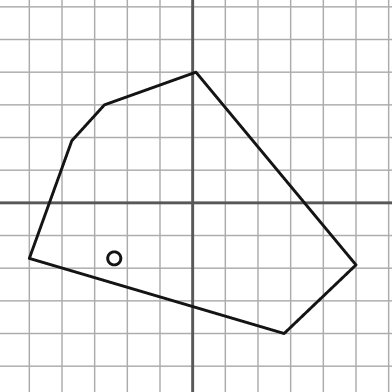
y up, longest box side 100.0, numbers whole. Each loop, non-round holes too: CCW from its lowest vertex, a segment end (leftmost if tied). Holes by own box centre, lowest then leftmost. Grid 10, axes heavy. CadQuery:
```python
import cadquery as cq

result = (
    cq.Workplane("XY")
    .moveTo(28.0, -40.0)
    .lineTo(50.0, -19.0)
    .lineTo(1.0, 40.0)
    .lineTo(-27.0, 30.0)
    .lineTo(-37.0, 19.0)
    .lineTo(-50.0, -17.0)
    .close()
    .moveTo(-24.0, -17.0)
    .circle(2.0)
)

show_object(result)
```